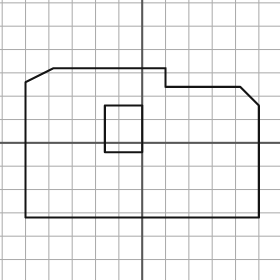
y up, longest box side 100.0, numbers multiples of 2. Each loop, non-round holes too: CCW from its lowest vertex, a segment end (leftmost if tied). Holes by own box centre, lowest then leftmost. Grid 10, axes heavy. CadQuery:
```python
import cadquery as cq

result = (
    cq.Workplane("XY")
    .moveTo(-50.0, -32.0)
    .lineTo(50.0, -32.0)
    .lineTo(50.0, 16.0)
    .lineTo(42.0, 24.0)
    .lineTo(10.0, 24.0)
    .lineTo(10.0, 32.0)
    .lineTo(-38.0, 32.0)
    .lineTo(-50.0, 26.0)
    .close()
    .moveTo(-16.0, -4.0)
    .lineTo(0.0, -4.0)
    .lineTo(0.0, 16.0)
    .lineTo(-16.0, 16.0)
    .close()
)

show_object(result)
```